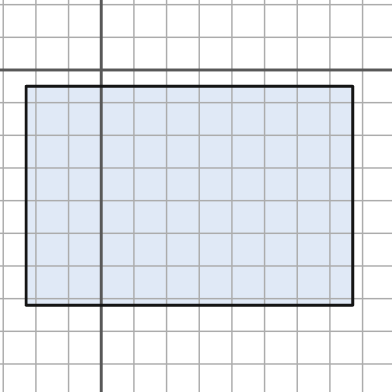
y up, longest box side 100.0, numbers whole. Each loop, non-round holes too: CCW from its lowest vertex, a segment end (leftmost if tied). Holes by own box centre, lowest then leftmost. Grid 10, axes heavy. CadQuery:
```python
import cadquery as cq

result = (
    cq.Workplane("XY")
    .moveTo(-23.0, -72.0)
    .lineTo(77.0, -72.0)
    .lineTo(77.0, -5.0)
    .lineTo(-23.0, -5.0)
    .close()
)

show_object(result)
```